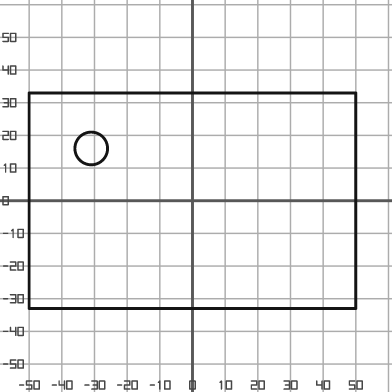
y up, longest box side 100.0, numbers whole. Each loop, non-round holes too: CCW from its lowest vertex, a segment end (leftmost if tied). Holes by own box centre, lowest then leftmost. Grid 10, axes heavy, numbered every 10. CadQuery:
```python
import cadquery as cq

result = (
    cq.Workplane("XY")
    .moveTo(-50.0, -33.0)
    .lineTo(50.0, -33.0)
    .lineTo(50.0, 33.0)
    .lineTo(-50.0, 33.0)
    .close()
    .moveTo(-31.0, 16.0)
    .circle(5.0)
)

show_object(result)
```